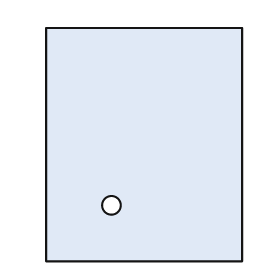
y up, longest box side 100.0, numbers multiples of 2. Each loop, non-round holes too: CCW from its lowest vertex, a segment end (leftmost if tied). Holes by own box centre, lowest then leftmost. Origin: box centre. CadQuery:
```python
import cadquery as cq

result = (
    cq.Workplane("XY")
    .moveTo(-42.0, -50.0)
    .lineTo(42.0, -50.0)
    .lineTo(42.0, 50.0)
    .lineTo(-42.0, 50.0)
    .close()
    .moveTo(-14.0, -26.0)
    .circle(4.0)
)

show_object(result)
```